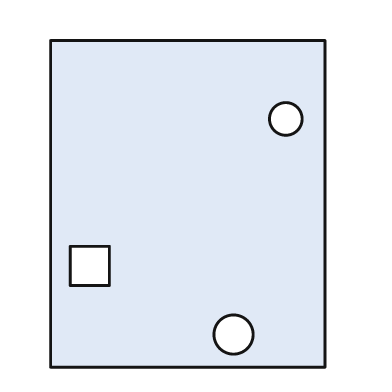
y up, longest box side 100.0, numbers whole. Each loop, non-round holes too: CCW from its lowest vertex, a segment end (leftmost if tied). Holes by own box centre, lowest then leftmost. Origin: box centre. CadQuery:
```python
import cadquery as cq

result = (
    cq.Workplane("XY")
    .moveTo(-42.0, -50.0)
    .lineTo(42.0, -50.0)
    .lineTo(42.0, 50.0)
    .lineTo(-42.0, 50.0)
    .close()
    .moveTo(14.0, -40.0)
    .circle(6.0)
    .moveTo(-36.0, -25.0)
    .lineTo(-24.0, -25.0)
    .lineTo(-24.0, -13.0)
    .lineTo(-36.0, -13.0)
    .close()
    .moveTo(30.0, 26.0)
    .circle(5.0)
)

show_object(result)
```